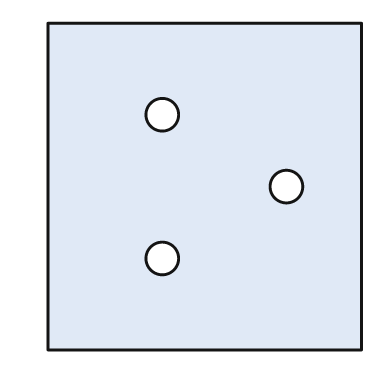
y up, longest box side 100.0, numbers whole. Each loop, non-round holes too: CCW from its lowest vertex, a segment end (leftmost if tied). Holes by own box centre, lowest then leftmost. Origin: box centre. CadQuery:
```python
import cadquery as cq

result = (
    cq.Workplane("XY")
    .moveTo(-48.0, -50.0)
    .lineTo(48.0, -50.0)
    .lineTo(48.0, 50.0)
    .lineTo(-48.0, 50.0)
    .close()
    .moveTo(-13.0, -22.0)
    .circle(5.0)
    .moveTo(25.0, 0.0)
    .circle(5.0)
    .moveTo(-13.0, 22.0)
    .circle(5.0)
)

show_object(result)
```